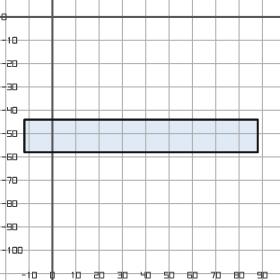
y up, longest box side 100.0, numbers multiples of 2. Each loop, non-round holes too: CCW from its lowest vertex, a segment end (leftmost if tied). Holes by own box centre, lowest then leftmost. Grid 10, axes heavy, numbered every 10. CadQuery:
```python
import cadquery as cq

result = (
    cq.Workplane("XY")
    .moveTo(-12.0, -58.0)
    .lineTo(88.0, -58.0)
    .lineTo(88.0, -44.0)
    .lineTo(-12.0, -44.0)
    .close()
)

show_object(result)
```